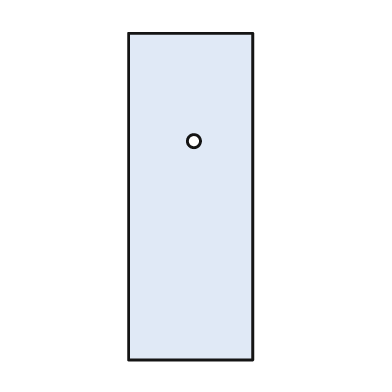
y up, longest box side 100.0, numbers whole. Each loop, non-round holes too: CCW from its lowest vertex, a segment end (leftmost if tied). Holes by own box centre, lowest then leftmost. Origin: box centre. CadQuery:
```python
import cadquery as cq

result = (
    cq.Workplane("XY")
    .moveTo(-19.0, -50.0)
    .lineTo(19.0, -50.0)
    .lineTo(19.0, 50.0)
    .lineTo(-19.0, 50.0)
    .close()
    .moveTo(1.0, 17.0)
    .circle(2.0)
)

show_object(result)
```